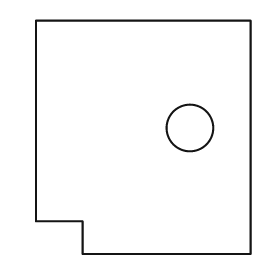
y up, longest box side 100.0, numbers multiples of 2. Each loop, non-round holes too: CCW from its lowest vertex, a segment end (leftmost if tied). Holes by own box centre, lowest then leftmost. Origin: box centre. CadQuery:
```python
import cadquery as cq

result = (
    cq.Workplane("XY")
    .moveTo(-26.0, -50.0)
    .lineTo(46.0, -50.0)
    .lineTo(46.0, 50.0)
    .lineTo(-46.0, 50.0)
    .lineTo(-46.0, -36.0)
    .lineTo(-26.0, -36.0)
    .close()
    .moveTo(20.0, 4.0)
    .circle(10.0)
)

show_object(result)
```